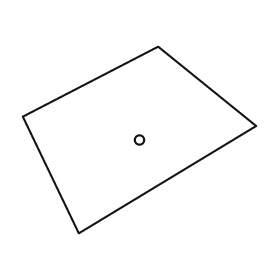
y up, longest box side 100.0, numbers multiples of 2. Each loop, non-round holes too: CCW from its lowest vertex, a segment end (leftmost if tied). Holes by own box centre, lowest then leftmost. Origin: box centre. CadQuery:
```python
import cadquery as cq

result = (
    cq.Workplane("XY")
    .moveTo(-26.0, -40.0)
    .lineTo(50.0, 6.0)
    .lineTo(8.0, 40.0)
    .lineTo(-50.0, 10.0)
    .close()
    .moveTo(0.0, 0.0)
    .circle(2.0)
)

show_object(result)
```